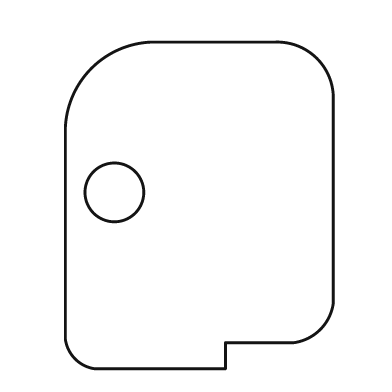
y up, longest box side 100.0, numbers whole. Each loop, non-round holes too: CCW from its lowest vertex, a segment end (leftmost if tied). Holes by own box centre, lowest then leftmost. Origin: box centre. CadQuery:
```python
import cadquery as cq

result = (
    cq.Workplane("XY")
    .moveTo(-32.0, -50.0)
    .lineTo(8.0, -50.0)
    .lineTo(8.0, -42.0)
    .lineTo(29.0, -42.0)
    .threePointArc((37.0, -38.0), (41.0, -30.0))
    .lineTo(41.0, 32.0)
    .threePointArc((36.0, 45.0), (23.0, 50.0))
    .lineTo(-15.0, 50.0)
    .threePointArc((-33.0, 42.0), (-41.0, 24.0))
    .lineTo(-41.0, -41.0)
    .threePointArc((-38.0, -47.0), (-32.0, -50.0))
    .close()
    .moveTo(-26.0, 4.0)
    .circle(9.0)
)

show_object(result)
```